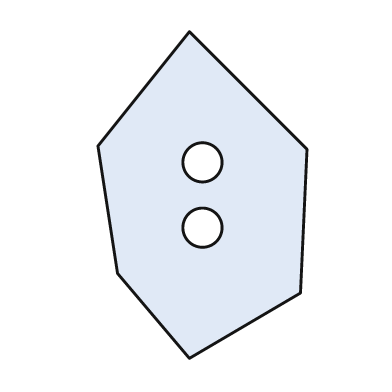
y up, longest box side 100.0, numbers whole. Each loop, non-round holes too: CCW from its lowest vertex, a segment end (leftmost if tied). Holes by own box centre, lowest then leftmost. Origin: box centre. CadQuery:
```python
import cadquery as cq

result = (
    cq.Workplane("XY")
    .moveTo(-4.0, -50.0)
    .lineTo(30.0, -30.0)
    .lineTo(32.0, 14.0)
    .lineTo(-4.0, 50.0)
    .lineTo(-32.0, 15.0)
    .lineTo(-26.0, -24.0)
    .close()
    .moveTo(0.0, -10.0)
    .circle(6.0)
    .moveTo(0.0, 10.0)
    .circle(6.0)
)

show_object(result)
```